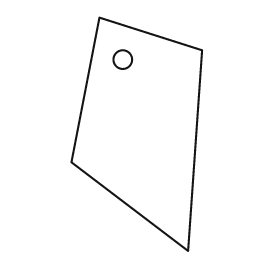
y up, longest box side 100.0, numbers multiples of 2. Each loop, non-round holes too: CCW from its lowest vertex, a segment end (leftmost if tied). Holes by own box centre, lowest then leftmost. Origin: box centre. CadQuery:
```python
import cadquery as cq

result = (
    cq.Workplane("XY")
    .moveTo(22.0, -50.0)
    .lineTo(28.0, 36.0)
    .lineTo(-16.0, 50.0)
    .lineTo(-28.0, -12.0)
    .close()
    .moveTo(-6.0, 32.0)
    .circle(4.0)
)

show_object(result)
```